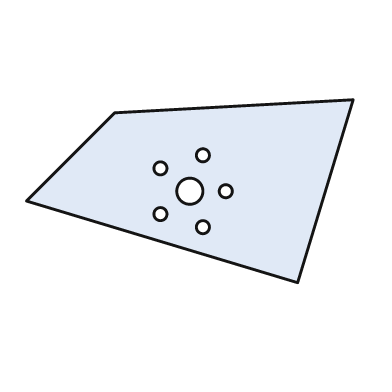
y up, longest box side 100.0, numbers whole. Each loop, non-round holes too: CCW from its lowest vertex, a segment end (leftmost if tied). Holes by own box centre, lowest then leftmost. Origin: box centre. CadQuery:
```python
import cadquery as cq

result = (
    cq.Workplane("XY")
    .moveTo(33.0, -28.0)
    .lineTo(50.0, 28.0)
    .lineTo(-23.0, 24.0)
    .lineTo(-50.0, -3.0)
    .close()
    .moveTo(4.0, -11.0)
    .circle(2.0)
    .moveTo(-9.0, -7.0)
    .circle(2.0)
    .moveTo(0.0, 0.0)
    .circle(4.0)
    .moveTo(11.0, 0.0)
    .circle(2.0)
    .moveTo(-9.0, 7.0)
    .circle(2.0)
    .moveTo(4.0, 11.0)
    .circle(2.0)
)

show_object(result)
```